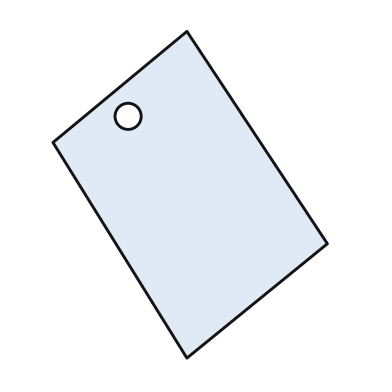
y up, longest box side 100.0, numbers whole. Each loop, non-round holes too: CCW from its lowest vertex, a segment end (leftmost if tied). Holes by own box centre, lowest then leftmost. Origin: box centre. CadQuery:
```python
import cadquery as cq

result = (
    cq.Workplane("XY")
    .moveTo(-1.0, -50.0)
    .lineTo(42.0, -15.0)
    .lineTo(-1.0, 50.0)
    .lineTo(-42.0, 16.0)
    .close()
    .moveTo(-19.0, 24.0)
    .circle(4.0)
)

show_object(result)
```